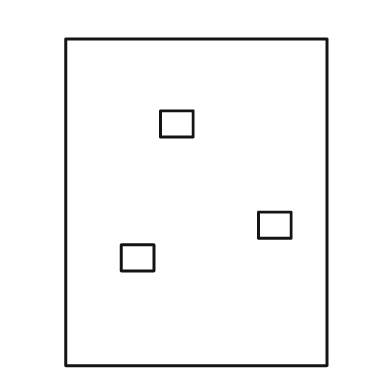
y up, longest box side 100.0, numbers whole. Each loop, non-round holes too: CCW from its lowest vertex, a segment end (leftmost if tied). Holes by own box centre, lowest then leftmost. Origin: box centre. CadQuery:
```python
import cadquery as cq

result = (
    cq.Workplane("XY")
    .moveTo(-40.0, -50.0)
    .lineTo(40.0, -50.0)
    .lineTo(40.0, 50.0)
    .lineTo(-40.0, 50.0)
    .close()
    .moveTo(-23.0, -21.0)
    .lineTo(-13.0, -21.0)
    .lineTo(-13.0, -13.0)
    .lineTo(-23.0, -13.0)
    .close()
    .moveTo(19.0, -11.0)
    .lineTo(29.0, -11.0)
    .lineTo(29.0, -3.0)
    .lineTo(19.0, -3.0)
    .close()
    .moveTo(-11.0, 20.0)
    .lineTo(-1.0, 20.0)
    .lineTo(-1.0, 28.0)
    .lineTo(-11.0, 28.0)
    .close()
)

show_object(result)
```